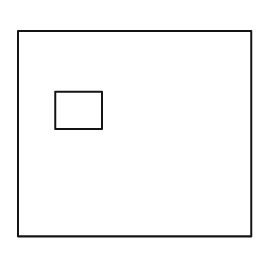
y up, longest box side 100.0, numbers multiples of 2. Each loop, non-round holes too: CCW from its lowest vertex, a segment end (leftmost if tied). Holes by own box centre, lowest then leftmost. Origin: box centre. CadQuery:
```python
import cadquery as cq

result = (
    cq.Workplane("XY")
    .moveTo(-50.0, -44.0)
    .lineTo(50.0, -44.0)
    .lineTo(50.0, 44.0)
    .lineTo(-50.0, 44.0)
    .close()
    .moveTo(-34.0, 2.0)
    .lineTo(-14.0, 2.0)
    .lineTo(-14.0, 18.0)
    .lineTo(-34.0, 18.0)
    .close()
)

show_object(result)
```